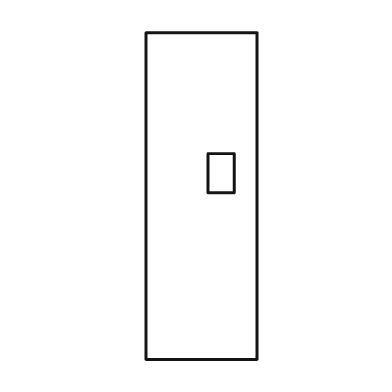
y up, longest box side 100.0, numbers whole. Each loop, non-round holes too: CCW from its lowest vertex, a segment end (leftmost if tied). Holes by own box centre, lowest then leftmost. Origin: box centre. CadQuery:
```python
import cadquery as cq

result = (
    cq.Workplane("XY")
    .moveTo(-17.0, -50.0)
    .lineTo(17.0, -50.0)
    .lineTo(17.0, 50.0)
    .lineTo(-17.0, 50.0)
    .close()
    .moveTo(2.0, 1.0)
    .lineTo(10.0, 1.0)
    .lineTo(10.0, 13.0)
    .lineTo(2.0, 13.0)
    .close()
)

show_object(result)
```